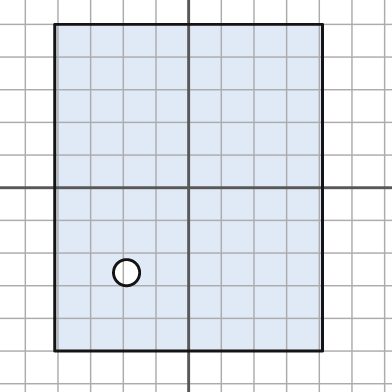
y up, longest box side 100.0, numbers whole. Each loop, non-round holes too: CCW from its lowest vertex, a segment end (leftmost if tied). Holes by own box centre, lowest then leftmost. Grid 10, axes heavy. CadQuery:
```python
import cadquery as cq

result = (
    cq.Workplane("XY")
    .moveTo(-41.0, -50.0)
    .lineTo(41.0, -50.0)
    .lineTo(41.0, 50.0)
    .lineTo(-41.0, 50.0)
    .close()
    .moveTo(-19.0, -26.0)
    .circle(4.0)
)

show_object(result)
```